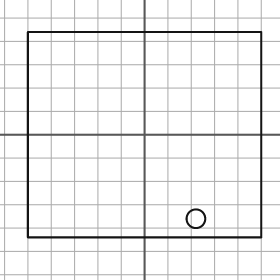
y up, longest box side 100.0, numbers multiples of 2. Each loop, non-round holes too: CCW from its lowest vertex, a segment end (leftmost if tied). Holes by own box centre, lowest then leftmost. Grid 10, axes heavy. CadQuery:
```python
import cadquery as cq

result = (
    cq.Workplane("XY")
    .moveTo(-50.0, -44.0)
    .lineTo(50.0, -44.0)
    .lineTo(50.0, 44.0)
    .lineTo(-50.0, 44.0)
    .close()
    .moveTo(22.0, -36.0)
    .circle(4.0)
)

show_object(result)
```